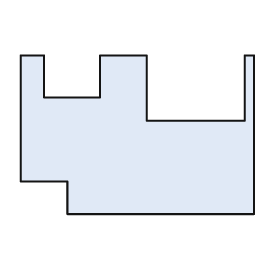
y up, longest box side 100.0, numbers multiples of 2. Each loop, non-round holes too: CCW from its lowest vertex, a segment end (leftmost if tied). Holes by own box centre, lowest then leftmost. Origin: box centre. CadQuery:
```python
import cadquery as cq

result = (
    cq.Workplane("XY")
    .moveTo(-30.0, -34.0)
    .lineTo(50.0, -34.0)
    .lineTo(50.0, 34.0)
    .lineTo(46.0, 34.0)
    .lineTo(46.0, 6.0)
    .lineTo(4.0, 6.0)
    .lineTo(4.0, 34.0)
    .lineTo(-16.0, 34.0)
    .lineTo(-16.0, 16.0)
    .lineTo(-40.0, 16.0)
    .lineTo(-40.0, 34.0)
    .lineTo(-50.0, 34.0)
    .lineTo(-50.0, -20.0)
    .lineTo(-30.0, -20.0)
    .close()
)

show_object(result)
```